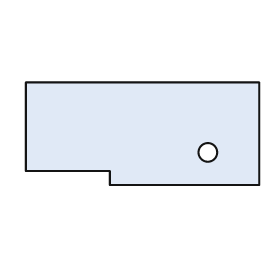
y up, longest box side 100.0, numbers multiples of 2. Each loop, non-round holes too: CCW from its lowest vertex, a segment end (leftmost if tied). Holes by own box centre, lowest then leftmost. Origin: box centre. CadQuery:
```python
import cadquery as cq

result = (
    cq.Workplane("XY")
    .moveTo(-14.0, -22.0)
    .lineTo(50.0, -22.0)
    .lineTo(50.0, 22.0)
    .lineTo(-50.0, 22.0)
    .lineTo(-50.0, -16.0)
    .lineTo(-14.0, -16.0)
    .close()
    .moveTo(28.0, -8.0)
    .circle(4.0)
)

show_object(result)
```